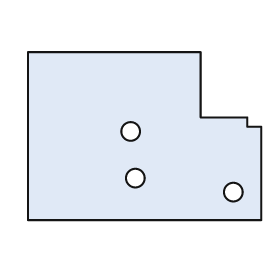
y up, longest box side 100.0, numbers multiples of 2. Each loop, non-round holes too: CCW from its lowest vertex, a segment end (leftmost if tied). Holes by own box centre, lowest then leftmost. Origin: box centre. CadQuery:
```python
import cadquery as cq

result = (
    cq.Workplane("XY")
    .moveTo(-50.0, -36.0)
    .lineTo(50.0, -36.0)
    .lineTo(50.0, 4.0)
    .lineTo(44.0, 4.0)
    .lineTo(44.0, 8.0)
    .lineTo(24.0, 8.0)
    .lineTo(24.0, 36.0)
    .lineTo(-50.0, 36.0)
    .close()
    .moveTo(38.0, -24.0)
    .circle(4.0)
    .moveTo(-4.0, -18.0)
    .circle(4.0)
    .moveTo(-6.0, 2.0)
    .circle(4.0)
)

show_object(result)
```